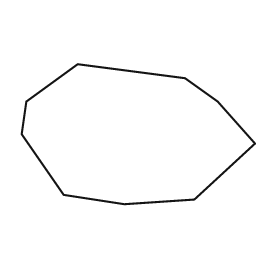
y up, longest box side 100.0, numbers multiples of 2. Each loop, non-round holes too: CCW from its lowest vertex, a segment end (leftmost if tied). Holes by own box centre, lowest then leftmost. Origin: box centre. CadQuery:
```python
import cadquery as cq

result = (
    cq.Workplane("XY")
    .moveTo(-6.0, -30.0)
    .lineTo(24.0, -28.0)
    .lineTo(50.0, -4.0)
    .lineTo(34.0, 14.0)
    .lineTo(20.0, 24.0)
    .lineTo(-26.0, 30.0)
    .lineTo(-48.0, 14.0)
    .lineTo(-50.0, 0.0)
    .lineTo(-32.0, -26.0)
    .close()
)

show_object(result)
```